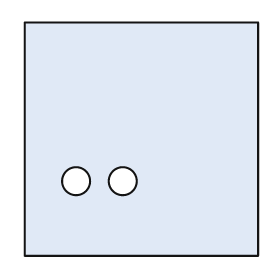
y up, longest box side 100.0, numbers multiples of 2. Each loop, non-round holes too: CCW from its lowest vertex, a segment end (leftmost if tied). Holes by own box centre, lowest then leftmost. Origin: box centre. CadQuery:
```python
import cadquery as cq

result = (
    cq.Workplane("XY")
    .moveTo(-50.0, -50.0)
    .lineTo(50.0, -50.0)
    .lineTo(50.0, 50.0)
    .lineTo(-50.0, 50.0)
    .close()
    .moveTo(-28.0, -18.0)
    .circle(6.0)
    .moveTo(-8.0, -18.0)
    .circle(6.0)
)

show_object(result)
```